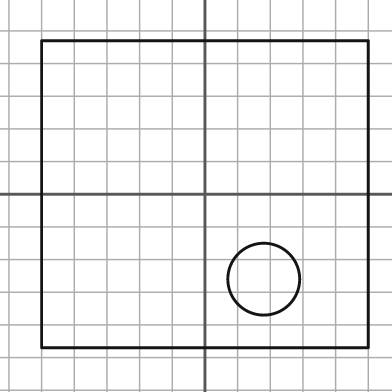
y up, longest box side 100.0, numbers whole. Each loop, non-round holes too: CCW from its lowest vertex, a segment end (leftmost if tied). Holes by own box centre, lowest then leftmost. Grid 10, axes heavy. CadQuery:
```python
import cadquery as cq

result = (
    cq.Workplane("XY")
    .moveTo(-50.0, -47.0)
    .lineTo(50.0, -47.0)
    .lineTo(50.0, 47.0)
    .lineTo(-50.0, 47.0)
    .close()
    .moveTo(18.0, -26.0)
    .circle(11.0)
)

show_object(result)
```